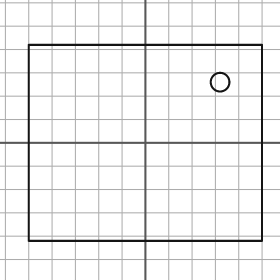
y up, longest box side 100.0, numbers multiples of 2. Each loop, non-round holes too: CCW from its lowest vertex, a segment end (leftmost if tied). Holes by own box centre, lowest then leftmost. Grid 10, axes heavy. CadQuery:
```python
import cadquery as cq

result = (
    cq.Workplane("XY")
    .moveTo(-50.0, -42.0)
    .lineTo(50.0, -42.0)
    .lineTo(50.0, 42.0)
    .lineTo(-50.0, 42.0)
    .close()
    .moveTo(32.0, 26.0)
    .circle(4.0)
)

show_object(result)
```